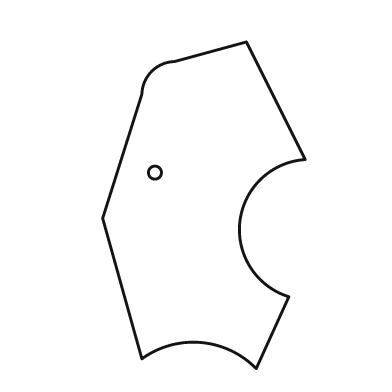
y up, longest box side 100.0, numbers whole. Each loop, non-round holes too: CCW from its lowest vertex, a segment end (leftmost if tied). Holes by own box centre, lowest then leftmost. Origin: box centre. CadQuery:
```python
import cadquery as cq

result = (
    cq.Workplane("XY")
    .moveTo(16.0, -50.0)
    .lineTo(26.0, -28.0)
    .threePointArc((11.0, -5.0), (31.0, 14.0))
    .lineTo(13.0, 50.0)
    .lineTo(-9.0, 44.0)
    .threePointArc((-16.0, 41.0), (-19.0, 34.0))
    .lineTo(-31.0, -4.0)
    .lineTo(-19.0, -47.0)
    .threePointArc((-1.0, -42.0), (16.0, -50.0))
    .close()
    .moveTo(-15.0, 10.0)
    .circle(2.0)
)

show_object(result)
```